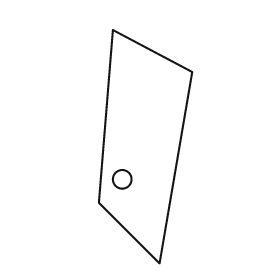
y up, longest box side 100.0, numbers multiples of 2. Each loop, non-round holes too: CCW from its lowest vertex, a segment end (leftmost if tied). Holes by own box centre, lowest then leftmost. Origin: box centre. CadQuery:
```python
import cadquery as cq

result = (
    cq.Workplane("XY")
    .moveTo(6.0, -50.0)
    .lineTo(20.0, 32.0)
    .lineTo(-14.0, 50.0)
    .lineTo(-20.0, -24.0)
    .close()
    .moveTo(-10.0, -14.0)
    .circle(4.0)
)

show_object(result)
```